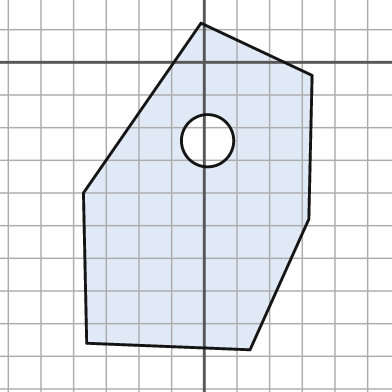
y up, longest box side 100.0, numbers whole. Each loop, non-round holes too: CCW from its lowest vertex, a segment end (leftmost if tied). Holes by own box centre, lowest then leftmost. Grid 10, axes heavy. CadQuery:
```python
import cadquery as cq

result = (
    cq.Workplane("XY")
    .moveTo(14.0, -88.0)
    .lineTo(32.0, -48.0)
    .lineTo(33.0, -4.0)
    .lineTo(-1.0, 12.0)
    .lineTo(-37.0, -40.0)
    .lineTo(-36.0, -86.0)
    .close()
    .moveTo(1.0, -24.0)
    .circle(8.0)
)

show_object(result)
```